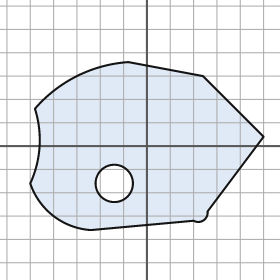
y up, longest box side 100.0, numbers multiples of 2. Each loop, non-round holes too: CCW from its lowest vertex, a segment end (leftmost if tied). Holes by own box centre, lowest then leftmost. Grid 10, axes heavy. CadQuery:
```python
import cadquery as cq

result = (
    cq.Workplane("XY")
    .moveTo(-24.0, -36.0)
    .lineTo(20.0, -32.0)
    .threePointArc((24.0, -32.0), (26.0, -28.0))
    .lineTo(50.0, 4.0)
    .lineTo(24.0, 30.0)
    .lineTo(-8.0, 36.0)
    .threePointArc((-30.0, 30.0), (-48.0, 16.0))
    .threePointArc((-46.0, 0.0), (-50.0, -16.0))
    .threePointArc((-40.0, -30.0), (-24.0, -36.0))
    .close()
    .moveTo(-14.0, -16.0)
    .circle(8.0)
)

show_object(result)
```